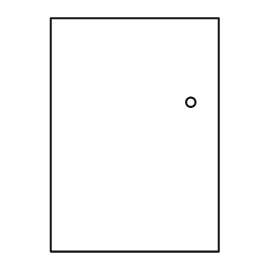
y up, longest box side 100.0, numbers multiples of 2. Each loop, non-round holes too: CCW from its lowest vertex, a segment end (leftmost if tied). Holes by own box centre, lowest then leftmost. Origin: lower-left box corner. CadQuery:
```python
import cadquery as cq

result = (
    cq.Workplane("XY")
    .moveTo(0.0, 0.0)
    .lineTo(72.0, 0.0)
    .lineTo(72.0, 100.0)
    .lineTo(0.0, 100.0)
    .close()
    .moveTo(60.0, 64.0)
    .circle(2.0)
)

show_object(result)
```